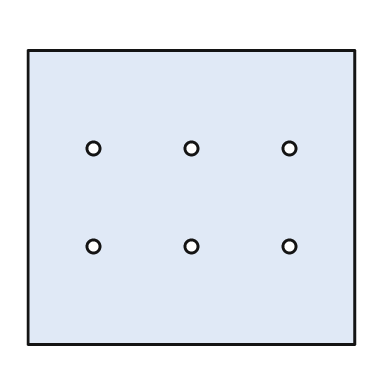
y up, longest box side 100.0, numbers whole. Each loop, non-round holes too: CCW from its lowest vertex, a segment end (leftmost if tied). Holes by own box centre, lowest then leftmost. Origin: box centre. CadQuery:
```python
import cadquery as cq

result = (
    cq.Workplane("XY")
    .moveTo(-50.0, -45.0)
    .lineTo(50.0, -45.0)
    .lineTo(50.0, 45.0)
    .lineTo(-50.0, 45.0)
    .close()
    .moveTo(-30.0, -15.0)
    .circle(2.0)
    .moveTo(0.0, -15.0)
    .circle(2.0)
    .moveTo(30.0, -15.0)
    .circle(2.0)
    .moveTo(-30.0, 15.0)
    .circle(2.0)
    .moveTo(0.0, 15.0)
    .circle(2.0)
    .moveTo(30.0, 15.0)
    .circle(2.0)
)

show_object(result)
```